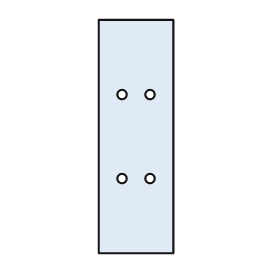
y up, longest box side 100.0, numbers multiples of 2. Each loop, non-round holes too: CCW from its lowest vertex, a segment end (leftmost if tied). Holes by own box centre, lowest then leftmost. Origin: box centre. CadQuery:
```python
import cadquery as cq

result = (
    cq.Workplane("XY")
    .moveTo(-16.0, -50.0)
    .lineTo(16.0, -50.0)
    .lineTo(16.0, 50.0)
    .lineTo(-16.0, 50.0)
    .close()
    .moveTo(-6.0, -18.0)
    .circle(2.0)
    .moveTo(6.0, -18.0)
    .circle(2.0)
    .moveTo(-6.0, 18.0)
    .circle(2.0)
    .moveTo(6.0, 18.0)
    .circle(2.0)
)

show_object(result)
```